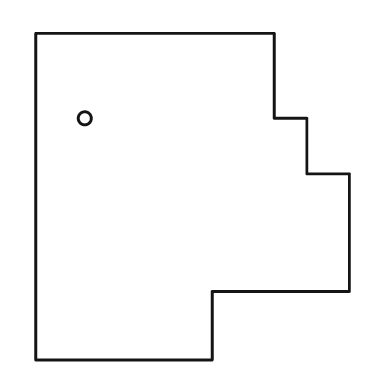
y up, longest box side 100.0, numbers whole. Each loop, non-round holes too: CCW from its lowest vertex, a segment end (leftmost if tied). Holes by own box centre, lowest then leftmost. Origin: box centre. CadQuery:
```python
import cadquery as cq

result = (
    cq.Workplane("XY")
    .moveTo(-48.0, -50.0)
    .lineTo(6.0, -50.0)
    .lineTo(6.0, -29.0)
    .lineTo(48.0, -29.0)
    .lineTo(48.0, 7.0)
    .lineTo(35.0, 7.0)
    .lineTo(35.0, 24.0)
    .lineTo(25.0, 24.0)
    .lineTo(25.0, 50.0)
    .lineTo(-48.0, 50.0)
    .close()
    .moveTo(-33.0, 24.0)
    .circle(2.0)
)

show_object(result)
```